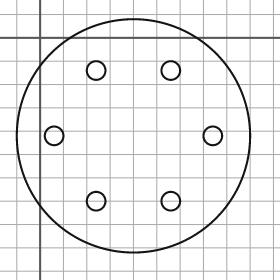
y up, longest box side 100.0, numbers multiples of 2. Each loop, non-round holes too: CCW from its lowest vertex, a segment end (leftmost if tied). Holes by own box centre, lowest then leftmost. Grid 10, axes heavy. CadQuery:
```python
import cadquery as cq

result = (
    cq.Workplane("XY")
    .moveTo(40.0, -42.0)
    .circle(50.0)
    .moveTo(24.0, -70.0)
    .circle(4.0)
    .moveTo(56.0, -70.0)
    .circle(4.0)
    .moveTo(6.0, -42.0)
    .circle(4.0)
    .moveTo(74.0, -42.0)
    .circle(4.0)
    .moveTo(24.0, -14.0)
    .circle(4.0)
    .moveTo(56.0, -14.0)
    .circle(4.0)
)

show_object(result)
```